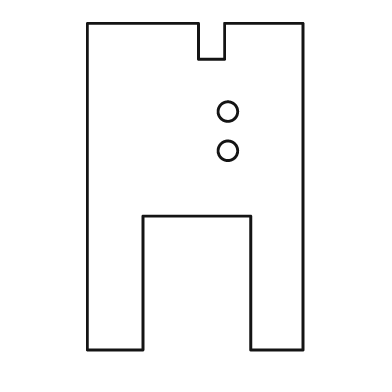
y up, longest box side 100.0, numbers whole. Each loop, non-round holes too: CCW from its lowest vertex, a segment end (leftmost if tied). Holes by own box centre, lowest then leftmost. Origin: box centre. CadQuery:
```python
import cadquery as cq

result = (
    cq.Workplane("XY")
    .moveTo(-33.0, -50.0)
    .lineTo(-16.0, -50.0)
    .lineTo(-16.0, -9.0)
    .lineTo(17.0, -9.0)
    .lineTo(17.0, -50.0)
    .lineTo(33.0, -50.0)
    .lineTo(33.0, 50.0)
    .lineTo(9.0, 50.0)
    .lineTo(9.0, 39.0)
    .lineTo(1.0, 39.0)
    .lineTo(1.0, 50.0)
    .lineTo(-33.0, 50.0)
    .close()
    .moveTo(10.0, 11.0)
    .circle(3.0)
    .moveTo(10.0, 23.0)
    .circle(3.0)
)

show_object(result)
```